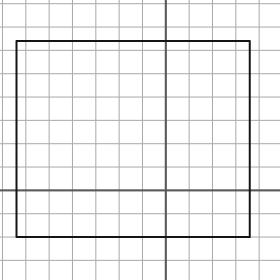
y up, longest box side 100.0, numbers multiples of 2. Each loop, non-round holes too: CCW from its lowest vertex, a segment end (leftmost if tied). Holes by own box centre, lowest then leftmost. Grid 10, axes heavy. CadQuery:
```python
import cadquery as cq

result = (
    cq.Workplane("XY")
    .moveTo(-64.0, -20.0)
    .lineTo(36.0, -20.0)
    .lineTo(36.0, 64.0)
    .lineTo(-64.0, 64.0)
    .close()
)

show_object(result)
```